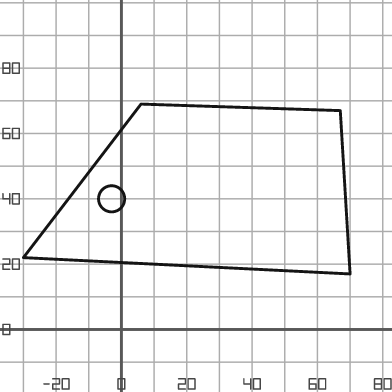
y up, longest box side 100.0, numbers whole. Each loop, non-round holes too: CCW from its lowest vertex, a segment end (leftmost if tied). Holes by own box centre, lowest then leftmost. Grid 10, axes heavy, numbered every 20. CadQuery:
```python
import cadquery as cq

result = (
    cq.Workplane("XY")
    .moveTo(70.0, 17.0)
    .lineTo(67.0, 67.0)
    .lineTo(6.0, 69.0)
    .lineTo(-30.0, 22.0)
    .close()
    .moveTo(-3.0, 40.0)
    .circle(4.0)
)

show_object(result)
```